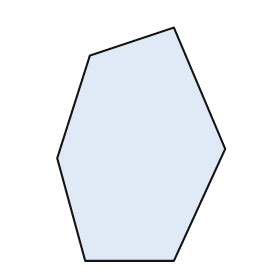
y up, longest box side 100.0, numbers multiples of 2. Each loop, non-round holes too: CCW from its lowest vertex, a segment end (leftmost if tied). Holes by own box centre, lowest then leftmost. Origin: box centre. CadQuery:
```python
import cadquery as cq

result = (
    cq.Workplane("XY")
    .moveTo(-24.0, -50.0)
    .lineTo(14.0, -50.0)
    .lineTo(36.0, -2.0)
    .lineTo(14.0, 50.0)
    .lineTo(-22.0, 38.0)
    .lineTo(-36.0, -6.0)
    .close()
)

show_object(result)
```